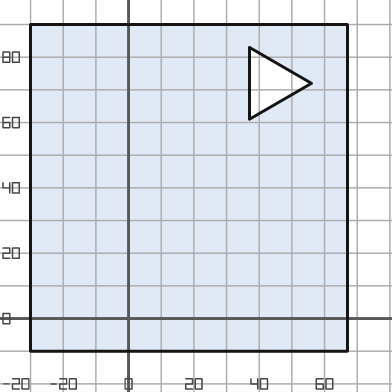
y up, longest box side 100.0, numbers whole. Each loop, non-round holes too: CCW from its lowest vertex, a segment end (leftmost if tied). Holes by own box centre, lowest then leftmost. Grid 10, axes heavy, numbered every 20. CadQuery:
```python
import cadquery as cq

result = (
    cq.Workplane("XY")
    .moveTo(-30.0, -10.0)
    .lineTo(67.0, -10.0)
    .lineTo(67.0, 90.0)
    .lineTo(-30.0, 90.0)
    .close()
    .moveTo(37.0, 61.0)
    .lineTo(56.0, 72.0)
    .lineTo(37.0, 83.0)
    .close()
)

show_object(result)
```